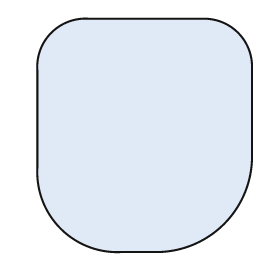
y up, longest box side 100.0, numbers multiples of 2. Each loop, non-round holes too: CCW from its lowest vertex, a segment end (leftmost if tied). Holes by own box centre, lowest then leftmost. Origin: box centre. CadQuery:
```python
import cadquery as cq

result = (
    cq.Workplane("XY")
    .moveTo(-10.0, -50.0)
    .lineTo(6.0, -50.0)
    .threePointArc((34.0, -38.0), (46.0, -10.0))
    .lineTo(46.0, 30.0)
    .threePointArc((40.0, 44.0), (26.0, 50.0))
    .lineTo(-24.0, 50.0)
    .threePointArc((-40.0, 44.0), (-46.0, 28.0))
    .lineTo(-46.0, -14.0)
    .threePointArc((-36.0, -40.0), (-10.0, -50.0))
    .close()
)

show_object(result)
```